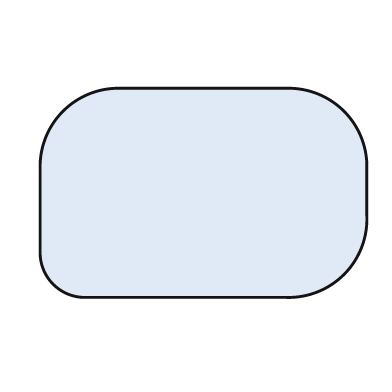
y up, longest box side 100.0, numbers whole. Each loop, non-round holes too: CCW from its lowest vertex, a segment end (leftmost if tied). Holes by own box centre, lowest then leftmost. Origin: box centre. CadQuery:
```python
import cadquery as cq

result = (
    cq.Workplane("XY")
    .moveTo(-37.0, -32.0)
    .lineTo(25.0, -32.0)
    .threePointArc((43.0, -25.0), (50.0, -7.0))
    .lineTo(50.0, 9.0)
    .threePointArc((43.0, 25.0), (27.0, 32.0))
    .lineTo(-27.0, 32.0)
    .threePointArc((-43.0, 25.0), (-50.0, 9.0))
    .lineTo(-50.0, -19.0)
    .threePointArc((-46.0, -28.0), (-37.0, -32.0))
    .close()
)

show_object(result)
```